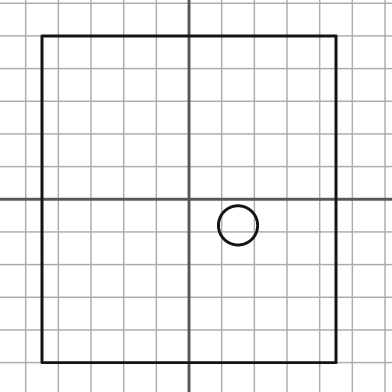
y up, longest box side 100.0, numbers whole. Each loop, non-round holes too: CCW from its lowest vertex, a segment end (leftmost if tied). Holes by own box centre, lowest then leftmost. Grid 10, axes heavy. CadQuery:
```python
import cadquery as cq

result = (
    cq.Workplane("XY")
    .moveTo(-45.0, -50.0)
    .lineTo(45.0, -50.0)
    .lineTo(45.0, 50.0)
    .lineTo(-45.0, 50.0)
    .close()
    .moveTo(15.0, -8.0)
    .circle(6.0)
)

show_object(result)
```